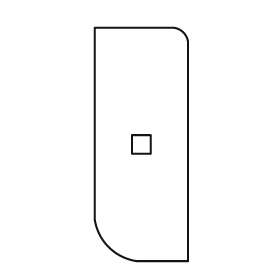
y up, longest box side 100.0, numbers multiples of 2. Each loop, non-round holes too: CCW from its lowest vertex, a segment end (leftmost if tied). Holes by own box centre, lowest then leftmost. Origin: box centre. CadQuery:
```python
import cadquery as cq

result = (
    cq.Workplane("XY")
    .moveTo(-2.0, -50.0)
    .lineTo(20.0, -50.0)
    .lineTo(20.0, 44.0)
    .threePointArc((18.0, 48.0), (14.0, 50.0))
    .lineTo(-20.0, 50.0)
    .lineTo(-20.0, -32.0)
    .threePointArc((-14.0, -44.0), (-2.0, -50.0))
    .close()
    .moveTo(-4.0, -4.0)
    .lineTo(4.0, -4.0)
    .lineTo(4.0, 4.0)
    .lineTo(-4.0, 4.0)
    .close()
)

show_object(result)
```